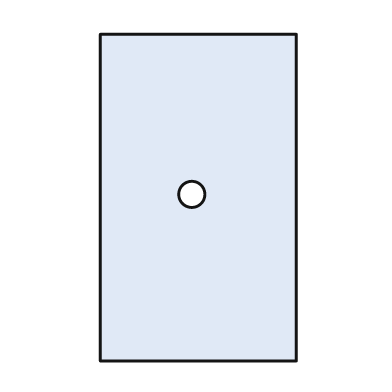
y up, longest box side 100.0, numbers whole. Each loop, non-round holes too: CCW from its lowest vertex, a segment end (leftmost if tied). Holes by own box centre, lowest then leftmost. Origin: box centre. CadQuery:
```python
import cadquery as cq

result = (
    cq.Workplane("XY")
    .moveTo(-30.0, -50.0)
    .lineTo(30.0, -50.0)
    .lineTo(30.0, 50.0)
    .lineTo(-30.0, 50.0)
    .close()
    .moveTo(-2.0, 1.0)
    .circle(4.0)
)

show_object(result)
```